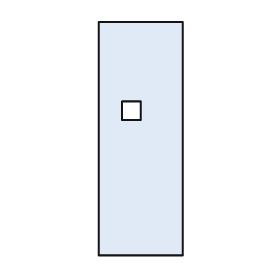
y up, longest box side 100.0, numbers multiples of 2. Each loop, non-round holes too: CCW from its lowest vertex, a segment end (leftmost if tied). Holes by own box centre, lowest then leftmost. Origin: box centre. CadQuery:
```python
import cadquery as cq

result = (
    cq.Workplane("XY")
    .moveTo(-18.0, -50.0)
    .lineTo(18.0, -50.0)
    .lineTo(18.0, 50.0)
    .lineTo(-18.0, 50.0)
    .close()
    .moveTo(-8.0, 8.0)
    .lineTo(0.0, 8.0)
    .lineTo(0.0, 16.0)
    .lineTo(-8.0, 16.0)
    .close()
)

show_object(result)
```